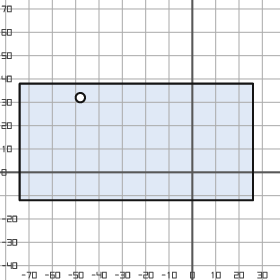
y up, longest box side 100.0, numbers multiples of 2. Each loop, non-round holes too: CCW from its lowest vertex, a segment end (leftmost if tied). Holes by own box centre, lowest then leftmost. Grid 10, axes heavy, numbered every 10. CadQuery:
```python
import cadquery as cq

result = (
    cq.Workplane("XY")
    .moveTo(-74.0, -12.0)
    .lineTo(26.0, -12.0)
    .lineTo(26.0, 38.0)
    .lineTo(-74.0, 38.0)
    .close()
    .moveTo(-48.0, 32.0)
    .circle(2.0)
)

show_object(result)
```